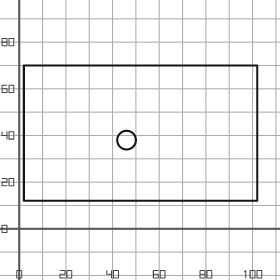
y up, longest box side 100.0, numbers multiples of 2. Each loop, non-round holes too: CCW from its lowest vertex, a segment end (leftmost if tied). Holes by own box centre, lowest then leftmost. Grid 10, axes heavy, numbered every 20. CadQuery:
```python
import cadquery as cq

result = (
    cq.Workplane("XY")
    .moveTo(2.0, 12.0)
    .lineTo(102.0, 12.0)
    .lineTo(102.0, 70.0)
    .lineTo(2.0, 70.0)
    .close()
    .moveTo(46.0, 38.0)
    .circle(4.0)
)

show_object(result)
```